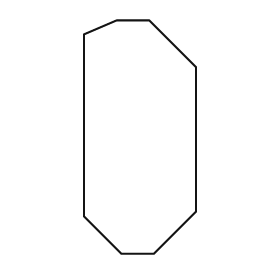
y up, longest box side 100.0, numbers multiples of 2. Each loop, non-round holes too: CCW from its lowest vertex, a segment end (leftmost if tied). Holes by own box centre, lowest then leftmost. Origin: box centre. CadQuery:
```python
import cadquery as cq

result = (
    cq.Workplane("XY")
    .moveTo(-8.0, -50.0)
    .lineTo(6.0, -50.0)
    .lineTo(24.0, -32.0)
    .lineTo(24.0, 30.0)
    .lineTo(4.0, 50.0)
    .lineTo(-10.0, 50.0)
    .lineTo(-24.0, 44.0)
    .lineTo(-24.0, -34.0)
    .close()
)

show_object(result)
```